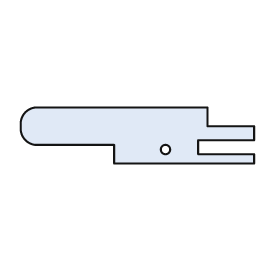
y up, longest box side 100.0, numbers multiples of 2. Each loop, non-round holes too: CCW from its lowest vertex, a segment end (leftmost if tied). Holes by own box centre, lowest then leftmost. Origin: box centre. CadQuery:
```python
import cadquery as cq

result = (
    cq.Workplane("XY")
    .moveTo(-10.0, -12.0)
    .lineTo(50.0, -12.0)
    .lineTo(50.0, -8.0)
    .lineTo(26.0, -8.0)
    .lineTo(26.0, -2.0)
    .lineTo(50.0, -2.0)
    .lineTo(50.0, 4.0)
    .lineTo(30.0, 4.0)
    .lineTo(30.0, 12.0)
    .lineTo(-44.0, 12.0)
    .threePointArc((-48.0, 10.0), (-50.0, 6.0))
    .lineTo(-50.0, 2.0)
    .threePointArc((-48.0, -2.0), (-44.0, -4.0))
    .lineTo(-10.0, -4.0)
    .close()
    .moveTo(12.0, -6.0)
    .circle(2.0)
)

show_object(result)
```